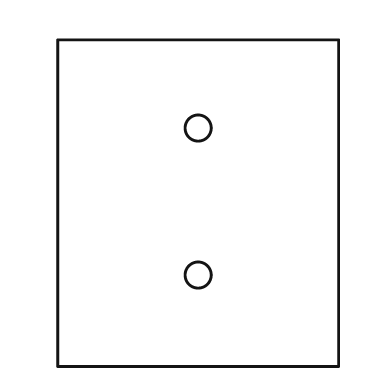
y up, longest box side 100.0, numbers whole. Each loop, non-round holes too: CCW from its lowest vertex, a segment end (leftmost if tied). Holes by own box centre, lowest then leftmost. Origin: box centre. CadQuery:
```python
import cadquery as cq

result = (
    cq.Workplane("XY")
    .moveTo(-43.0, -50.0)
    .lineTo(43.0, -50.0)
    .lineTo(43.0, 50.0)
    .lineTo(-43.0, 50.0)
    .close()
    .moveTo(0.0, -22.0)
    .circle(4.0)
    .moveTo(0.0, 23.0)
    .circle(4.0)
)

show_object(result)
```